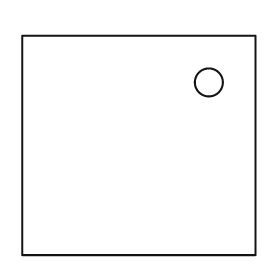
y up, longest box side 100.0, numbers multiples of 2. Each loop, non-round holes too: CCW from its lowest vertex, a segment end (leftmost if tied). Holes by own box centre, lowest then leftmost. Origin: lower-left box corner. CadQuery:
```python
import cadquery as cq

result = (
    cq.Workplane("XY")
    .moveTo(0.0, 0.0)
    .lineTo(100.0, 0.0)
    .lineTo(100.0, 94.0)
    .lineTo(0.0, 94.0)
    .close()
    .moveTo(80.0, 74.0)
    .circle(6.0)
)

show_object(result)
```